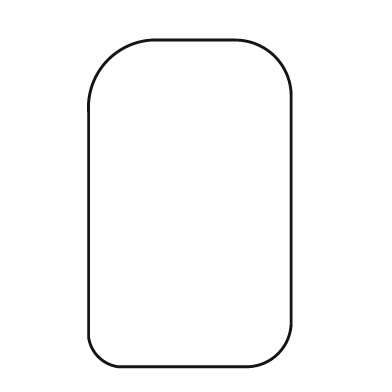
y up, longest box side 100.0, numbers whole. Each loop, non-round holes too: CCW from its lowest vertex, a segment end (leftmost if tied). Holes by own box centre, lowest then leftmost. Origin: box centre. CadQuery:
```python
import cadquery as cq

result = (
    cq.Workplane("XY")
    .moveTo(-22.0, -50.0)
    .lineTo(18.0, -50.0)
    .threePointArc((27.0, -46.0), (31.0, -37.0))
    .lineTo(31.0, 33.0)
    .threePointArc((26.0, 45.0), (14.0, 50.0))
    .lineTo(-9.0, 50.0)
    .threePointArc((-25.0, 44.0), (-31.0, 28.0))
    .lineTo(-31.0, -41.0)
    .threePointArc((-28.0, -47.0), (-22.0, -50.0))
    .close()
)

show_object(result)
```